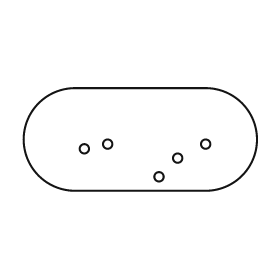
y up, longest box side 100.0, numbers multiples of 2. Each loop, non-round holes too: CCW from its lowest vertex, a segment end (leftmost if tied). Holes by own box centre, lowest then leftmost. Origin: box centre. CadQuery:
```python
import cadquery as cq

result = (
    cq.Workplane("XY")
    .moveTo(-28.0, -22.0)
    .lineTo(28.0, -22.0)
    .threePointArc((50.0, 0.0), (28.0, 22.0))
    .lineTo(-28.0, 22.0)
    .threePointArc((-50.0, 0.0), (-28.0, -22.0))
    .close()
    .moveTo(8.0, -16.0)
    .circle(2.0)
    .moveTo(16.0, -8.0)
    .circle(2.0)
    .moveTo(-24.0, -4.0)
    .circle(2.0)
    .moveTo(-14.0, -2.0)
    .circle(2.0)
    .moveTo(28.0, -2.0)
    .circle(2.0)
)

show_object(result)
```